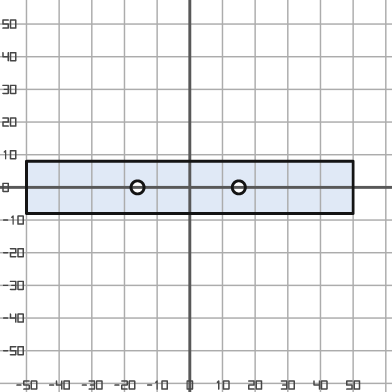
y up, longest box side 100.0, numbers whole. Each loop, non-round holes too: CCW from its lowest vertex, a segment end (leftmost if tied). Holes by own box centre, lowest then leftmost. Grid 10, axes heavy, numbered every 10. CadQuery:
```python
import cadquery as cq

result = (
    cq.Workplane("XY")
    .moveTo(-50.0, -8.0)
    .lineTo(50.0, -8.0)
    .lineTo(50.0, 8.0)
    .lineTo(-50.0, 8.0)
    .close()
    .moveTo(-16.0, 0.0)
    .circle(2.0)
    .moveTo(15.0, 0.0)
    .circle(2.0)
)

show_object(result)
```